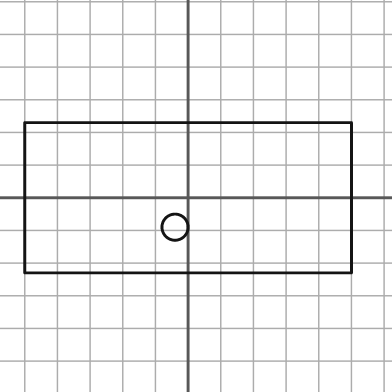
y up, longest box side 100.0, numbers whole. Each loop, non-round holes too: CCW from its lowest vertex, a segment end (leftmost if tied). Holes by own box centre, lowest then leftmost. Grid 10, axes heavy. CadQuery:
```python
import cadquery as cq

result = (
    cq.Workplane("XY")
    .moveTo(-50.0, -23.0)
    .lineTo(50.0, -23.0)
    .lineTo(50.0, 23.0)
    .lineTo(-50.0, 23.0)
    .close()
    .moveTo(-4.0, -9.0)
    .circle(4.0)
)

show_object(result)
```